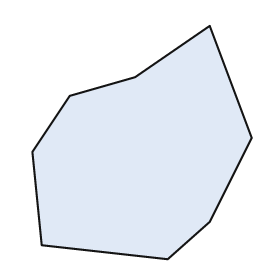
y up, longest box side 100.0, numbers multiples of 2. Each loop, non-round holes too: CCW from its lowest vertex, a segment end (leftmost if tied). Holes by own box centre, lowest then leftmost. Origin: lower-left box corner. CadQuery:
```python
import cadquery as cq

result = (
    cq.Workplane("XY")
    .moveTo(58.0, 0.0)
    .lineTo(76.0, 16.0)
    .lineTo(94.0, 52.0)
    .lineTo(76.0, 100.0)
    .lineTo(44.0, 78.0)
    .lineTo(16.0, 70.0)
    .lineTo(0.0, 46.0)
    .lineTo(4.0, 6.0)
    .close()
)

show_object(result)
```